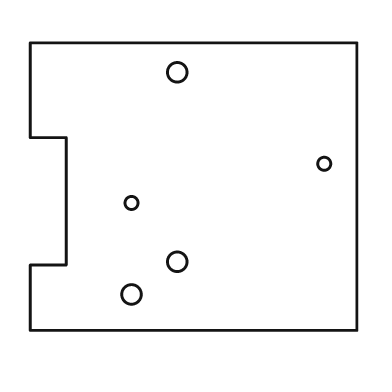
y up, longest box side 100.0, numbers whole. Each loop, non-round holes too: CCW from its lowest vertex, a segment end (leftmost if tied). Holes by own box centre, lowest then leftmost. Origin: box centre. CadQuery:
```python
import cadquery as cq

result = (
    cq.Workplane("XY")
    .moveTo(-50.0, -44.0)
    .lineTo(50.0, -44.0)
    .lineTo(50.0, 44.0)
    .lineTo(-50.0, 44.0)
    .lineTo(-50.0, 15.0)
    .lineTo(-39.0, 15.0)
    .lineTo(-39.0, -24.0)
    .lineTo(-50.0, -24.0)
    .close()
    .moveTo(-19.0, -33.0)
    .circle(3.0)
    .moveTo(-5.0, -23.0)
    .circle(3.0)
    .moveTo(-19.0, -5.0)
    .circle(2.0)
    .moveTo(40.0, 7.0)
    .circle(2.0)
    .moveTo(-5.0, 35.0)
    .circle(3.0)
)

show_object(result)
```